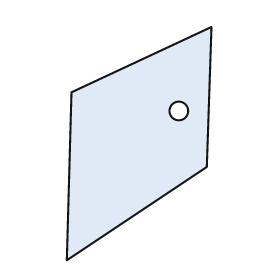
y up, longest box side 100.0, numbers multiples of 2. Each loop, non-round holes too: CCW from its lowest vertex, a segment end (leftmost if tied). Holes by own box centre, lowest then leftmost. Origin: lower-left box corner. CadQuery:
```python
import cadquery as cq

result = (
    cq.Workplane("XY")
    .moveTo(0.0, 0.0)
    .lineTo(60.0, 40.0)
    .lineTo(62.0, 100.0)
    .lineTo(2.0, 72.0)
    .close()
    .moveTo(48.0, 64.0)
    .circle(4.0)
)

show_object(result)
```